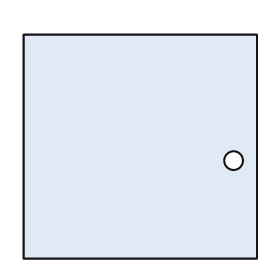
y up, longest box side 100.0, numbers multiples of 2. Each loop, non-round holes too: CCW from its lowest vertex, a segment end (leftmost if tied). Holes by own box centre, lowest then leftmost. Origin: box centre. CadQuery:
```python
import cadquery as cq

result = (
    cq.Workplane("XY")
    .moveTo(-50.0, -48.0)
    .lineTo(50.0, -48.0)
    .lineTo(50.0, 48.0)
    .lineTo(-50.0, 48.0)
    .close()
    .moveTo(40.0, -6.0)
    .circle(4.0)
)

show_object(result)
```